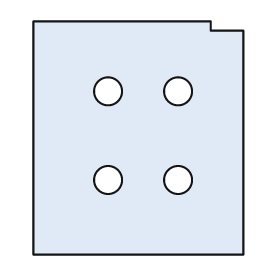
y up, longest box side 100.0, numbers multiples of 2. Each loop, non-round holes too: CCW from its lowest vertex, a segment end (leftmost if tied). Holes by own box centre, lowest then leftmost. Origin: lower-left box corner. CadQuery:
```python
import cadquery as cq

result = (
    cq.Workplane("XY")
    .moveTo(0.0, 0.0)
    .lineTo(90.0, 0.0)
    .lineTo(90.0, 96.0)
    .lineTo(76.0, 96.0)
    .lineTo(76.0, 100.0)
    .lineTo(0.0, 100.0)
    .close()
    .moveTo(32.0, 32.0)
    .circle(6.0)
    .moveTo(62.0, 32.0)
    .circle(6.0)
    .moveTo(32.0, 70.0)
    .circle(6.0)
    .moveTo(62.0, 70.0)
    .circle(6.0)
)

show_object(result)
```